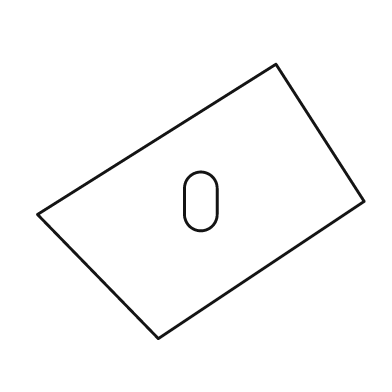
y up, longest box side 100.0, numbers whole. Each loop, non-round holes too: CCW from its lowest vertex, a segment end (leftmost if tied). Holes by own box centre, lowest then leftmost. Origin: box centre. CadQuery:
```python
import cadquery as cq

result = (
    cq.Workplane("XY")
    .moveTo(-13.0, -42.0)
    .lineTo(50.0, 0.0)
    .lineTo(23.0, 42.0)
    .lineTo(-50.0, -4.0)
    .close()
    .moveTo(-5.0, -4.0)
    .threePointArc((0.0, -9.0), (5.0, -4.0))
    .lineTo(5.0, 4.0)
    .threePointArc((0.0, 9.0), (-5.0, 4.0))
    .close()
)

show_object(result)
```